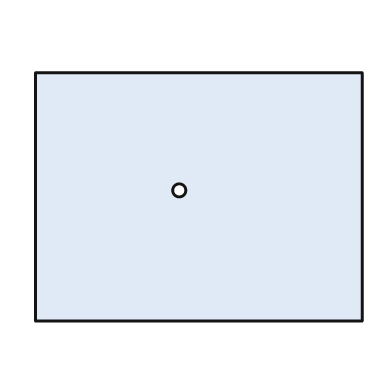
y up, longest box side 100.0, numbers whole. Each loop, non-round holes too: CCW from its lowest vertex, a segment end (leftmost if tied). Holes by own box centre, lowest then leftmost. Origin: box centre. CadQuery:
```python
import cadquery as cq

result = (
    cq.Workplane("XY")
    .moveTo(-50.0, -38.0)
    .lineTo(50.0, -38.0)
    .lineTo(50.0, 38.0)
    .lineTo(-50.0, 38.0)
    .close()
    .moveTo(-6.0, 2.0)
    .circle(2.0)
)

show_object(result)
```